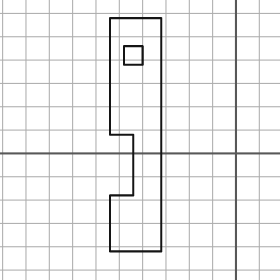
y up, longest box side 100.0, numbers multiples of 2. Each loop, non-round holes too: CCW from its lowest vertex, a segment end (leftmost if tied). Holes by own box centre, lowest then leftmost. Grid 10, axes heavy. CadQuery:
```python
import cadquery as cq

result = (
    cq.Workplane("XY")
    .moveTo(-54.0, -42.0)
    .lineTo(-32.0, -42.0)
    .lineTo(-32.0, 58.0)
    .lineTo(-54.0, 58.0)
    .lineTo(-54.0, 8.0)
    .lineTo(-44.0, 8.0)
    .lineTo(-44.0, -18.0)
    .lineTo(-54.0, -18.0)
    .close()
    .moveTo(-48.0, 38.0)
    .lineTo(-40.0, 38.0)
    .lineTo(-40.0, 46.0)
    .lineTo(-48.0, 46.0)
    .close()
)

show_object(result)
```